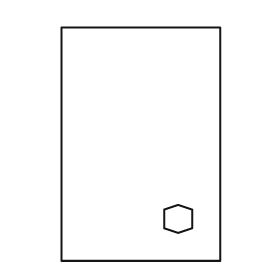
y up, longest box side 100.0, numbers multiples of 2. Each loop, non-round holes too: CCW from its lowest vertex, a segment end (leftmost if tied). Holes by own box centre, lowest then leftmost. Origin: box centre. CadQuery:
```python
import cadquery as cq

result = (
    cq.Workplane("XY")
    .moveTo(-34.0, -50.0)
    .lineTo(34.0, -50.0)
    .lineTo(34.0, 50.0)
    .lineTo(-34.0, 50.0)
    .close()
    .moveTo(16.0, -38.0)
    .lineTo(22.0, -36.0)
    .lineTo(22.0, -28.0)
    .lineTo(16.0, -26.0)
    .lineTo(10.0, -28.0)
    .lineTo(10.0, -36.0)
    .close()
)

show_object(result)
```